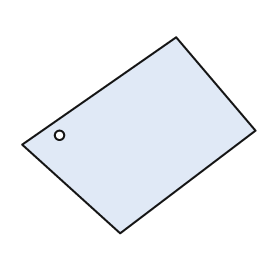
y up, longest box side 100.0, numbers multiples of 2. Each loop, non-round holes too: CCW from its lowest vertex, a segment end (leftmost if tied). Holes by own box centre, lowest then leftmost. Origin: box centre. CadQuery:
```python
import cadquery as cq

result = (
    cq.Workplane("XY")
    .moveTo(-8.0, -42.0)
    .lineTo(50.0, 2.0)
    .lineTo(16.0, 42.0)
    .lineTo(-50.0, -4.0)
    .close()
    .moveTo(-34.0, 0.0)
    .circle(2.0)
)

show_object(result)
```